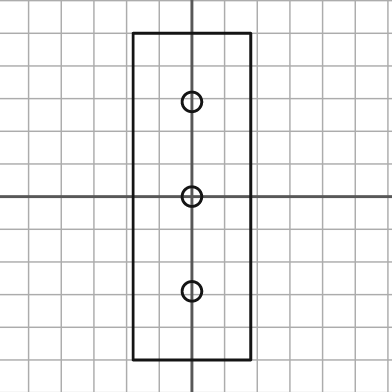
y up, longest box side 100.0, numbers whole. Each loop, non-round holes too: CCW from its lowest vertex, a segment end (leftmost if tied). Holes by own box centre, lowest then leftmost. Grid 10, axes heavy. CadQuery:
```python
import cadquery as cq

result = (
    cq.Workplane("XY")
    .moveTo(-18.0, -50.0)
    .lineTo(18.0, -50.0)
    .lineTo(18.0, 50.0)
    .lineTo(-18.0, 50.0)
    .close()
    .moveTo(0.0, -29.0)
    .circle(3.0)
    .moveTo(0.0, 0.0)
    .circle(3.0)
    .moveTo(0.0, 29.0)
    .circle(3.0)
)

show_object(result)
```